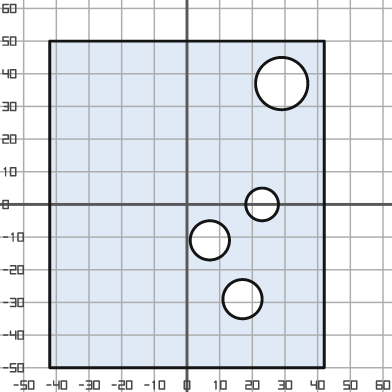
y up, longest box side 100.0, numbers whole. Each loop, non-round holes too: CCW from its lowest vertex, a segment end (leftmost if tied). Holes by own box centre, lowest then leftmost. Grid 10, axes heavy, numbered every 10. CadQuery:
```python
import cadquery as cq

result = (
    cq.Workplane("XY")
    .moveTo(-42.0, -50.0)
    .lineTo(42.0, -50.0)
    .lineTo(42.0, 50.0)
    .lineTo(-42.0, 50.0)
    .close()
    .moveTo(17.0, -29.0)
    .circle(6.0)
    .moveTo(7.0, -11.0)
    .circle(6.0)
    .moveTo(23.0, 0.0)
    .circle(5.0)
    .moveTo(29.0, 37.0)
    .circle(8.0)
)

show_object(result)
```